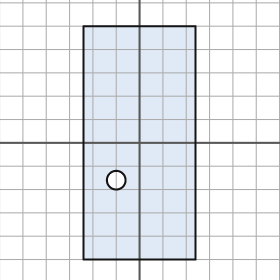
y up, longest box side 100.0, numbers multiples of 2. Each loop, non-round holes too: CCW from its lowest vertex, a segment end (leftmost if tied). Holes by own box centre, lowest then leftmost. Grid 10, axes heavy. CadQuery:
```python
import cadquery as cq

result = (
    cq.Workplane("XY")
    .moveTo(-24.0, -50.0)
    .lineTo(24.0, -50.0)
    .lineTo(24.0, 50.0)
    .lineTo(-24.0, 50.0)
    .close()
    .moveTo(-10.0, -16.0)
    .circle(4.0)
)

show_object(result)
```